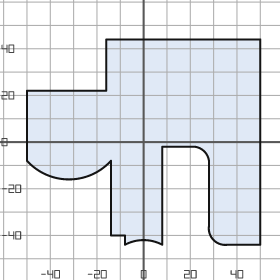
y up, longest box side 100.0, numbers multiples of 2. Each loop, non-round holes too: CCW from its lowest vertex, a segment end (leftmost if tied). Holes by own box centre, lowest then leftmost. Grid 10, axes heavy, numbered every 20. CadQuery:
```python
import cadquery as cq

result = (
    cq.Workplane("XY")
    .moveTo(-8.0, -44.0)
    .threePointArc((0.0, -42.0), (8.0, -44.0))
    .lineTo(8.0, -2.0)
    .lineTo(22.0, -2.0)
    .threePointArc((26.0, -4.0), (28.0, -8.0))
    .lineTo(28.0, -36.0)
    .threePointArc((30.0, -42.0), (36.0, -44.0))
    .lineTo(50.0, -44.0)
    .lineTo(50.0, 44.0)
    .lineTo(-16.0, 44.0)
    .lineTo(-16.0, 22.0)
    .lineTo(-50.0, 22.0)
    .lineTo(-50.0, -8.0)
    .threePointArc((-32.0, -16.0), (-14.0, -8.0))
    .lineTo(-14.0, -40.0)
    .lineTo(-8.0, -40.0)
    .close()
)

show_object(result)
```